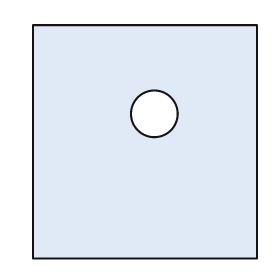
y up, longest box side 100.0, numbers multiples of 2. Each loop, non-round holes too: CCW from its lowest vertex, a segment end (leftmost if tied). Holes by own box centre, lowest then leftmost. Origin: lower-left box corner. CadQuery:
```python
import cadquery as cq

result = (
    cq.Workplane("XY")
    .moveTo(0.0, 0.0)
    .lineTo(96.0, 0.0)
    .lineTo(96.0, 100.0)
    .lineTo(0.0, 100.0)
    .close()
    .moveTo(52.0, 62.0)
    .circle(10.0)
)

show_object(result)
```